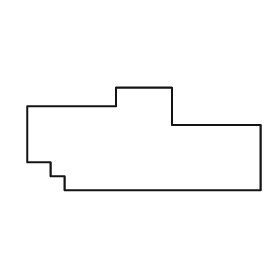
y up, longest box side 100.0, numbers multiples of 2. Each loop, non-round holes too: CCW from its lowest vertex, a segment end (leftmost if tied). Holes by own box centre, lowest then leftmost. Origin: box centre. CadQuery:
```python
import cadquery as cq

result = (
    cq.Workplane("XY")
    .moveTo(-34.0, -22.0)
    .lineTo(50.0, -22.0)
    .lineTo(50.0, 6.0)
    .lineTo(12.0, 6.0)
    .lineTo(12.0, 22.0)
    .lineTo(-12.0, 22.0)
    .lineTo(-12.0, 14.0)
    .lineTo(-50.0, 14.0)
    .lineTo(-50.0, -10.0)
    .lineTo(-40.0, -10.0)
    .lineTo(-40.0, -16.0)
    .lineTo(-34.0, -16.0)
    .close()
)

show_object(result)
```